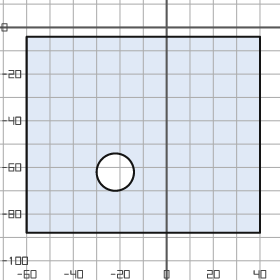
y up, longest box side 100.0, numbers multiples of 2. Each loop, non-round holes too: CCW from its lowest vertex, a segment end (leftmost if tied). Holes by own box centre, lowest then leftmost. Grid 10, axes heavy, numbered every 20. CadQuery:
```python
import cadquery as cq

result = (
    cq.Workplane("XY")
    .moveTo(-60.0, -88.0)
    .lineTo(40.0, -88.0)
    .lineTo(40.0, -4.0)
    .lineTo(-60.0, -4.0)
    .close()
    .moveTo(-22.0, -62.0)
    .circle(8.0)
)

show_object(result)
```